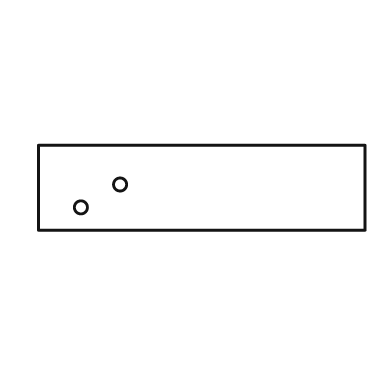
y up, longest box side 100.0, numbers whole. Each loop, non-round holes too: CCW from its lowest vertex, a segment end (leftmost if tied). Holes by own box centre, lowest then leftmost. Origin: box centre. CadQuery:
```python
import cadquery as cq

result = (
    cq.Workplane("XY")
    .moveTo(-50.0, -13.0)
    .lineTo(50.0, -13.0)
    .lineTo(50.0, 13.0)
    .lineTo(-50.0, 13.0)
    .close()
    .moveTo(-37.0, -6.0)
    .circle(2.0)
    .moveTo(-25.0, 1.0)
    .circle(2.0)
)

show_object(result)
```